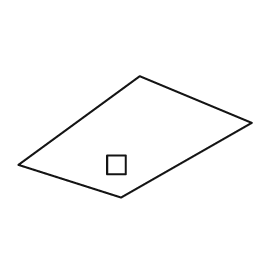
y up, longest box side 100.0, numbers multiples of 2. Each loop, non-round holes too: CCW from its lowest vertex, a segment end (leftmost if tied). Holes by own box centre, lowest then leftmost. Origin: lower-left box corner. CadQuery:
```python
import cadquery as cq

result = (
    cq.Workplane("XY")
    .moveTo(44.0, 0.0)
    .lineTo(100.0, 32.0)
    .lineTo(52.0, 52.0)
    .lineTo(0.0, 14.0)
    .close()
    .moveTo(38.0, 10.0)
    .lineTo(46.0, 10.0)
    .lineTo(46.0, 18.0)
    .lineTo(38.0, 18.0)
    .close()
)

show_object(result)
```